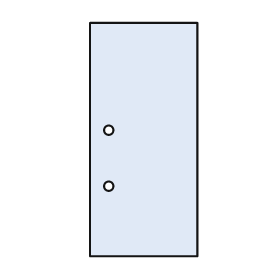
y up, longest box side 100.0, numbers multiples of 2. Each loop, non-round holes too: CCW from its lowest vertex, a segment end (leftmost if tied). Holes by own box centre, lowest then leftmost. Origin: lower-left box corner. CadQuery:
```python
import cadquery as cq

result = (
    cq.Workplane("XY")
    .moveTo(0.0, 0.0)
    .lineTo(46.0, 0.0)
    .lineTo(46.0, 100.0)
    .lineTo(0.0, 100.0)
    .close()
    .moveTo(8.0, 30.0)
    .circle(2.0)
    .moveTo(8.0, 54.0)
    .circle(2.0)
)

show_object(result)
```